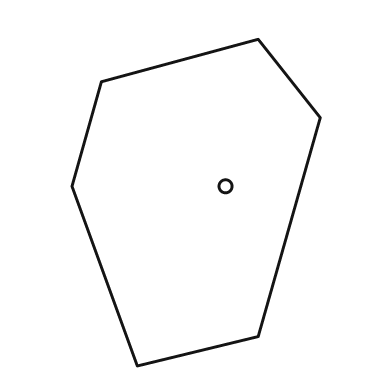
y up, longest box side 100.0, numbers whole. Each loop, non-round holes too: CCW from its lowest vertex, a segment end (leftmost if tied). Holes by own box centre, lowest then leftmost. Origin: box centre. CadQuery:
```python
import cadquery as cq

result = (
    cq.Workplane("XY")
    .moveTo(-18.0, -50.0)
    .lineTo(19.0, -41.0)
    .lineTo(38.0, 26.0)
    .lineTo(19.0, 50.0)
    .lineTo(-29.0, 37.0)
    .lineTo(-38.0, 5.0)
    .close()
    .moveTo(9.0, 5.0)
    .circle(2.0)
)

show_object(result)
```